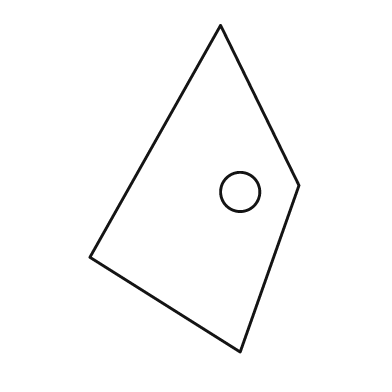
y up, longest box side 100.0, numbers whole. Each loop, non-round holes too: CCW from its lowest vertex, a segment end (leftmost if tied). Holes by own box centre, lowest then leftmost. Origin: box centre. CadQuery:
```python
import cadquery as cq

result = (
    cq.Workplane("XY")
    .moveTo(14.0, -50.0)
    .lineTo(32.0, 1.0)
    .lineTo(8.0, 50.0)
    .lineTo(-32.0, -21.0)
    .close()
    .moveTo(14.0, -1.0)
    .circle(6.0)
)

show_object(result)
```